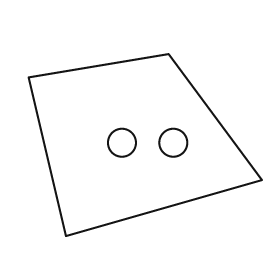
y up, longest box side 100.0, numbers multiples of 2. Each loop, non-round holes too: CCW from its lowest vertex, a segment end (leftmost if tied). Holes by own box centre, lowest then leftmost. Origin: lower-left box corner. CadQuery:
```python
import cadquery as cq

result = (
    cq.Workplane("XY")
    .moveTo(16.0, 0.0)
    .lineTo(100.0, 24.0)
    .lineTo(60.0, 78.0)
    .lineTo(0.0, 68.0)
    .close()
    .moveTo(40.0, 40.0)
    .circle(6.0)
    .moveTo(62.0, 40.0)
    .circle(6.0)
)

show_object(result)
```